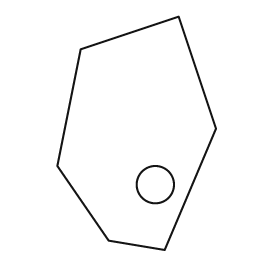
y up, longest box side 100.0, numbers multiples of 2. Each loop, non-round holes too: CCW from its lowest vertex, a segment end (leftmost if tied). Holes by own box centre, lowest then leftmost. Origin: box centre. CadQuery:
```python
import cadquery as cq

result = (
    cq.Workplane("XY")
    .moveTo(12.0, -50.0)
    .lineTo(34.0, 2.0)
    .lineTo(18.0, 50.0)
    .lineTo(-24.0, 36.0)
    .lineTo(-34.0, -14.0)
    .lineTo(-12.0, -46.0)
    .close()
    .moveTo(8.0, -22.0)
    .circle(8.0)
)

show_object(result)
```